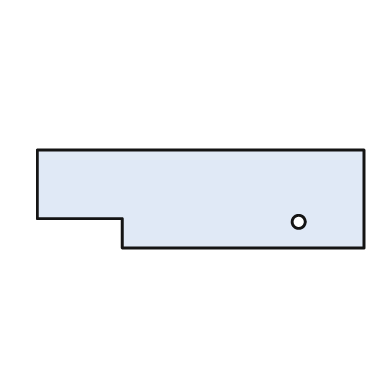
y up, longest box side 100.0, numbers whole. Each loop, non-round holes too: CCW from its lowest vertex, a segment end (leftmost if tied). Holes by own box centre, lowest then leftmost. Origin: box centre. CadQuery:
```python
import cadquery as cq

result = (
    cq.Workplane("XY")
    .moveTo(-24.0, -15.0)
    .lineTo(50.0, -15.0)
    .lineTo(50.0, 15.0)
    .lineTo(-50.0, 15.0)
    .lineTo(-50.0, -6.0)
    .lineTo(-24.0, -6.0)
    .close()
    .moveTo(30.0, -7.0)
    .circle(2.0)
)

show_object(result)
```